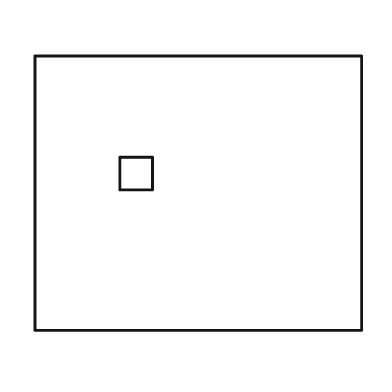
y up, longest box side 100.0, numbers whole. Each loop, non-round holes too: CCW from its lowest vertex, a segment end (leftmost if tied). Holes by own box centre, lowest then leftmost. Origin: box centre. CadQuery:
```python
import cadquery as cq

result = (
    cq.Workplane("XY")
    .moveTo(-50.0, -42.0)
    .lineTo(50.0, -42.0)
    .lineTo(50.0, 42.0)
    .lineTo(-50.0, 42.0)
    .close()
    .moveTo(-24.0, 1.0)
    .lineTo(-14.0, 1.0)
    .lineTo(-14.0, 11.0)
    .lineTo(-24.0, 11.0)
    .close()
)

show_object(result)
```